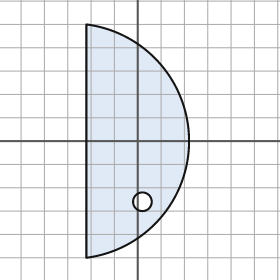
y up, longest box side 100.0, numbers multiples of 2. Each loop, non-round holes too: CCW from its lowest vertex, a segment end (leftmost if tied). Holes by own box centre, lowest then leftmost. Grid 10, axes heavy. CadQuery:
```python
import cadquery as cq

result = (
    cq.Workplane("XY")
    .moveTo(-22.0, -50.0)
    .threePointArc((22.0, 0.0), (-22.0, 50.0))
    .close()
    .moveTo(2.0, -26.0)
    .circle(4.0)
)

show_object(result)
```